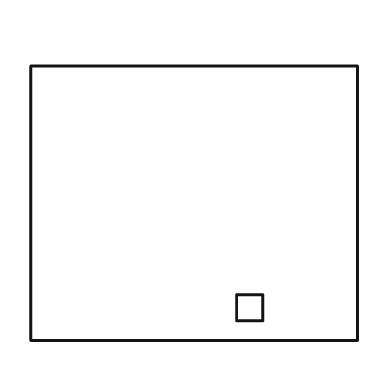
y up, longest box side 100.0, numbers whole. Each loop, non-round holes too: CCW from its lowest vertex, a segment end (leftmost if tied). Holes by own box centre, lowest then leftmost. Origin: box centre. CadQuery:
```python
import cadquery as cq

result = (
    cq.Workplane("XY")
    .moveTo(-50.0, -42.0)
    .lineTo(50.0, -42.0)
    .lineTo(50.0, 42.0)
    .lineTo(-50.0, 42.0)
    .close()
    .moveTo(13.0, -36.0)
    .lineTo(21.0, -36.0)
    .lineTo(21.0, -28.0)
    .lineTo(13.0, -28.0)
    .close()
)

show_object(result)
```